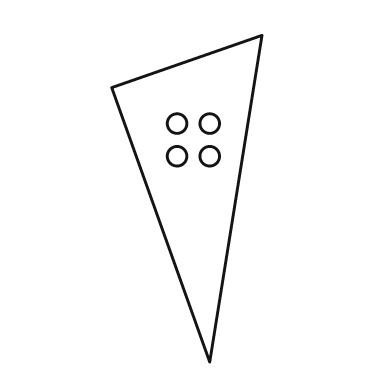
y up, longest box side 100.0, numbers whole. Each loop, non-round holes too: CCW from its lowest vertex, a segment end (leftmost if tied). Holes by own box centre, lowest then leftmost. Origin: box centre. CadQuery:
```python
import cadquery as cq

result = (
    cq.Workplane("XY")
    .moveTo(7.0, -50.0)
    .lineTo(23.0, 50.0)
    .lineTo(-23.0, 34.0)
    .close()
    .moveTo(-3.0, 13.0)
    .circle(3.0)
    .moveTo(7.0, 13.0)
    .circle(3.0)
    .moveTo(-3.0, 23.0)
    .circle(3.0)
    .moveTo(7.0, 23.0)
    .circle(3.0)
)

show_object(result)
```